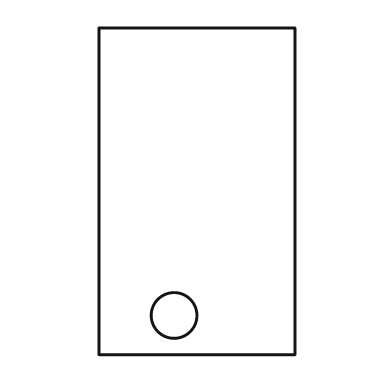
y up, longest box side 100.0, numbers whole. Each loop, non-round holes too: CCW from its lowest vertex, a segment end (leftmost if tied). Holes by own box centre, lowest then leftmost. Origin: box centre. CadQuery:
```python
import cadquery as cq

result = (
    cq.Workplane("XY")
    .moveTo(-30.0, -50.0)
    .lineTo(30.0, -50.0)
    .lineTo(30.0, 50.0)
    .lineTo(-30.0, 50.0)
    .close()
    .moveTo(-7.0, -38.0)
    .circle(7.0)
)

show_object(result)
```